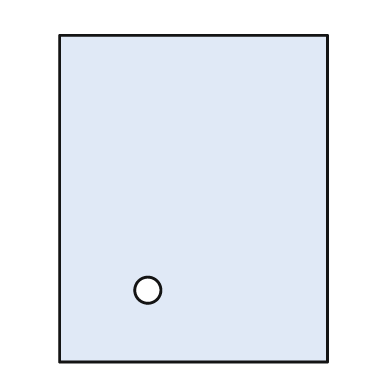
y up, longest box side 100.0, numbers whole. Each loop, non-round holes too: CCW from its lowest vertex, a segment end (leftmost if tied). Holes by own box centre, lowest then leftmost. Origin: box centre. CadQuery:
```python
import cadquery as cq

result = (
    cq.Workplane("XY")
    .moveTo(-41.0, -50.0)
    .lineTo(41.0, -50.0)
    .lineTo(41.0, 50.0)
    .lineTo(-41.0, 50.0)
    .close()
    .moveTo(-14.0, -28.0)
    .circle(4.0)
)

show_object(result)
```